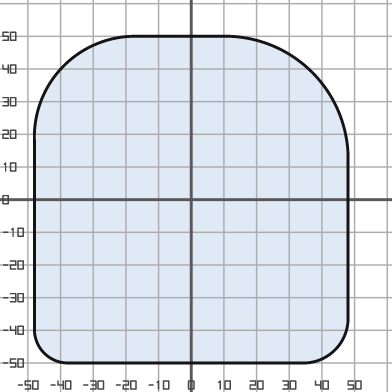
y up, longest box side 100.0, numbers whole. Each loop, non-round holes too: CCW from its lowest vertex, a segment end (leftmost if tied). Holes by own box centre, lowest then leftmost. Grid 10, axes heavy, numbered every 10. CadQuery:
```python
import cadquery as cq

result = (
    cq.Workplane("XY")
    .moveTo(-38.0, -50.0)
    .lineTo(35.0, -50.0)
    .threePointArc((44.0, -46.0), (48.0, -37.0))
    .lineTo(48.0, 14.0)
    .threePointArc((37.0, 39.0), (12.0, 50.0))
    .lineTo(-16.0, 50.0)
    .threePointArc((-39.0, 41.0), (-48.0, 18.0))
    .lineTo(-48.0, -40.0)
    .threePointArc((-45.0, -47.0), (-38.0, -50.0))
    .close()
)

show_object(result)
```